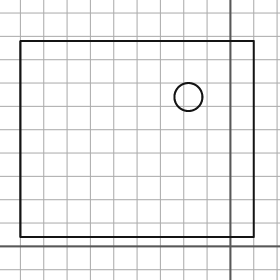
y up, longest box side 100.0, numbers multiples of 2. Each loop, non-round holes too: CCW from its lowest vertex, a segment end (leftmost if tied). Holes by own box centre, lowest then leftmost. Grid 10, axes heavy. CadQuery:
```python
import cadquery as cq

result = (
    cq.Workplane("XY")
    .moveTo(-90.0, 4.0)
    .lineTo(10.0, 4.0)
    .lineTo(10.0, 88.0)
    .lineTo(-90.0, 88.0)
    .close()
    .moveTo(-18.0, 64.0)
    .circle(6.0)
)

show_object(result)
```